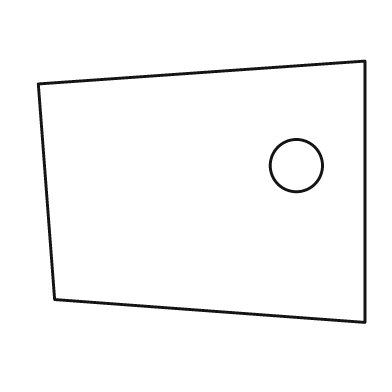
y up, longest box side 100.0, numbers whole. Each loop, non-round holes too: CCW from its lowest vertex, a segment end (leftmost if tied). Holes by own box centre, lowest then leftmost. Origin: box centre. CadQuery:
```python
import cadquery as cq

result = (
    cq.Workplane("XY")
    .moveTo(50.0, -40.0)
    .lineTo(50.0, 40.0)
    .lineTo(-50.0, 33.0)
    .lineTo(-45.0, -33.0)
    .close()
    .moveTo(29.0, 8.0)
    .circle(8.0)
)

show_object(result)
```